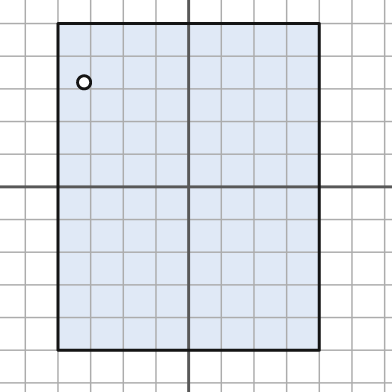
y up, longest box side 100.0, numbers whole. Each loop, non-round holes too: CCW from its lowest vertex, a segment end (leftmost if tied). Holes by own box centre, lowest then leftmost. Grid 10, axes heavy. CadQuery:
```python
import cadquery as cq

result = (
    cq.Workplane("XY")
    .moveTo(-40.0, -50.0)
    .lineTo(40.0, -50.0)
    .lineTo(40.0, 50.0)
    .lineTo(-40.0, 50.0)
    .close()
    .moveTo(-32.0, 32.0)
    .circle(2.0)
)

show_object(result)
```